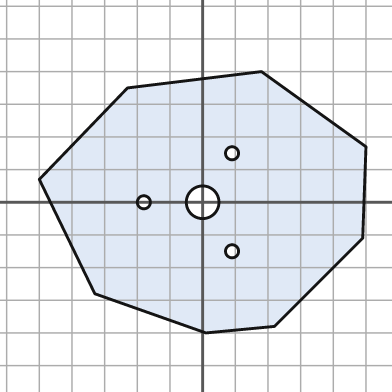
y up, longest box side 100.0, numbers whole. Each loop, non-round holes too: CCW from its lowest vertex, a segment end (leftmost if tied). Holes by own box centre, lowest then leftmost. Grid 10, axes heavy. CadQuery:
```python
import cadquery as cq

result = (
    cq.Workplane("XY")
    .moveTo(1.0, -40.0)
    .lineTo(22.0, -38.0)
    .lineTo(49.0, -11.0)
    .lineTo(50.0, 17.0)
    .lineTo(18.0, 40.0)
    .lineTo(-23.0, 35.0)
    .lineTo(-50.0, 7.0)
    .lineTo(-33.0, -28.0)
    .close()
    .moveTo(9.0, -15.0)
    .circle(2.0)
    .moveTo(-18.0, 0.0)
    .circle(2.0)
    .moveTo(0.0, 0.0)
    .circle(5.0)
    .moveTo(9.0, 15.0)
    .circle(2.0)
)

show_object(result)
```